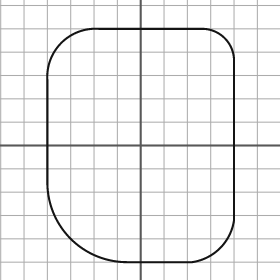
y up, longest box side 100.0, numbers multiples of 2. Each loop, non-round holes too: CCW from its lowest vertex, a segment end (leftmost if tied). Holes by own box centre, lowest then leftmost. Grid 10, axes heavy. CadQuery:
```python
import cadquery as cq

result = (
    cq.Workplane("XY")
    .moveTo(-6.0, -50.0)
    .lineTo(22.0, -50.0)
    .threePointArc((34.0, -44.0), (40.0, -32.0))
    .lineTo(40.0, 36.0)
    .threePointArc((36.0, 46.0), (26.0, 50.0))
    .lineTo(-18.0, 50.0)
    .threePointArc((-34.0, 44.0), (-40.0, 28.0))
    .lineTo(-40.0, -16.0)
    .threePointArc((-30.0, -40.0), (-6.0, -50.0))
    .close()
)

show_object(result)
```